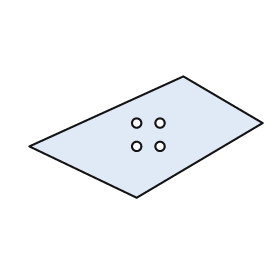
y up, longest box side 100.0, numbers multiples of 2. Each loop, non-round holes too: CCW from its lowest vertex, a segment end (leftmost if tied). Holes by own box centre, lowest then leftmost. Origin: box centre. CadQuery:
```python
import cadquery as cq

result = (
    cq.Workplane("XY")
    .moveTo(-4.0, -26.0)
    .lineTo(50.0, 6.0)
    .lineTo(16.0, 26.0)
    .lineTo(-50.0, -4.0)
    .close()
    .moveTo(-4.0, -4.0)
    .circle(2.0)
    .moveTo(6.0, -4.0)
    .circle(2.0)
    .moveTo(-4.0, 6.0)
    .circle(2.0)
    .moveTo(6.0, 6.0)
    .circle(2.0)
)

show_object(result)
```